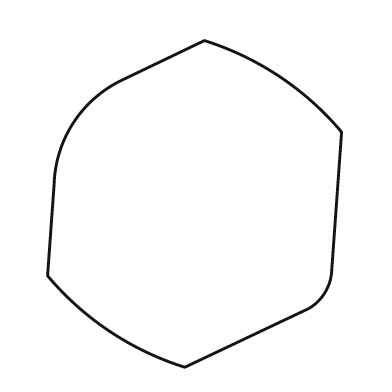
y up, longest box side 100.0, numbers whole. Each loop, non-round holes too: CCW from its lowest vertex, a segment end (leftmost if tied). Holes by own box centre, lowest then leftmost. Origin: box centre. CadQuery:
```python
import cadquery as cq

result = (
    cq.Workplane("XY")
    .moveTo(-3.0, -50.0)
    .lineTo(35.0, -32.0)
    .threePointArc((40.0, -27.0), (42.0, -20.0))
    .lineTo(45.0, 22.0)
    .threePointArc((26.0, 39.0), (3.0, 50.0))
    .lineTo(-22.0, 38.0)
    .threePointArc((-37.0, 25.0), (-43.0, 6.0))
    .lineTo(-45.0, -22.0)
    .threePointArc((-26.0, -39.0), (-3.0, -50.0))
    .close()
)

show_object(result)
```